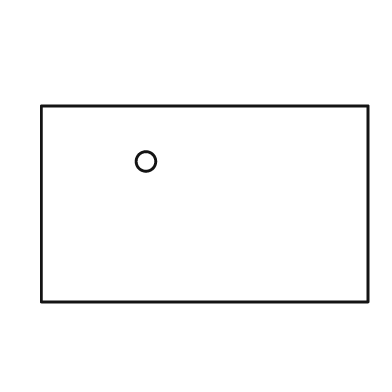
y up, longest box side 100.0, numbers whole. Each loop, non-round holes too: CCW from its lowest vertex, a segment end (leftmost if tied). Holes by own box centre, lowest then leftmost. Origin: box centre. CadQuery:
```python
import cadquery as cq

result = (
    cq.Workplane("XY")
    .moveTo(-50.0, -30.0)
    .lineTo(50.0, -30.0)
    .lineTo(50.0, 30.0)
    .lineTo(-50.0, 30.0)
    .close()
    .moveTo(-18.0, 13.0)
    .circle(3.0)
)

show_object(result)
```